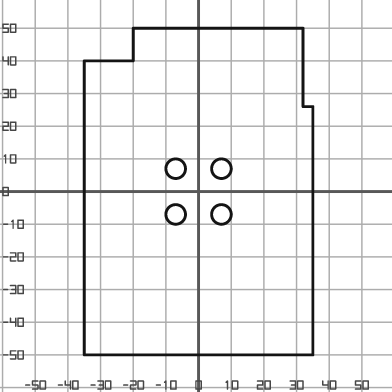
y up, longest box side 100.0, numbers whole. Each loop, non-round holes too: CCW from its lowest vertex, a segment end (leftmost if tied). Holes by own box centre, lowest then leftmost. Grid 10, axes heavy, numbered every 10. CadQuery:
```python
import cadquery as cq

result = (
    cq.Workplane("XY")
    .moveTo(-35.0, -50.0)
    .lineTo(35.0, -50.0)
    .lineTo(35.0, 26.0)
    .lineTo(32.0, 26.0)
    .lineTo(32.0, 50.0)
    .lineTo(-20.0, 50.0)
    .lineTo(-20.0, 40.0)
    .lineTo(-35.0, 40.0)
    .close()
    .moveTo(-7.0, -7.0)
    .circle(3.0)
    .moveTo(7.0, -7.0)
    .circle(3.0)
    .moveTo(-7.0, 7.0)
    .circle(3.0)
    .moveTo(7.0, 7.0)
    .circle(3.0)
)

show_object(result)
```